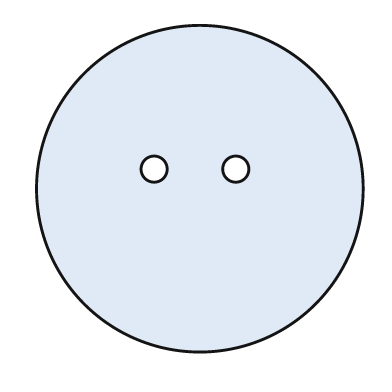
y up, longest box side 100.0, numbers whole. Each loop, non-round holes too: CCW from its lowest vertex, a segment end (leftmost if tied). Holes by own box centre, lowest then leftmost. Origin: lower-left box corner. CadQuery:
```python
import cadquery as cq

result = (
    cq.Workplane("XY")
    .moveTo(50.0, 50.0)
    .circle(50.0)
    .moveTo(36.0, 56.0)
    .circle(4.0)
    .moveTo(61.0, 56.0)
    .circle(4.0)
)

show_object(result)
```